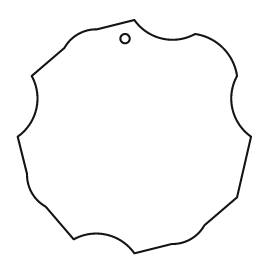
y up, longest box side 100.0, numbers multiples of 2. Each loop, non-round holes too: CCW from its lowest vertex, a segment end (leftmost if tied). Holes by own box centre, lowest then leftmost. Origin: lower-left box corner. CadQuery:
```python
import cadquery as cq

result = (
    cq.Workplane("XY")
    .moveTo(50.0, 0.0)
    .lineTo(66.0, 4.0)
    .threePointArc((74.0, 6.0), (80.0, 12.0))
    .lineTo(94.0, 24.0)
    .lineTo(100.0, 50.0)
    .threePointArc((92.0, 62.0), (94.0, 76.0))
    .threePointArc((88.0, 88.0), (76.0, 94.0))
    .threePointArc((62.0, 92.0), (50.0, 100.0))
    .lineTo(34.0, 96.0)
    .threePointArc((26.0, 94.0), (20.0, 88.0))
    .lineTo(6.0, 76.0)
    .threePointArc((8.0, 62.0), (0.0, 50.0))
    .lineTo(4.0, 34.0)
    .threePointArc((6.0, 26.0), (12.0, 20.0))
    .lineTo(24.0, 6.0)
    .threePointArc((38.0, 8.0), (50.0, 0.0))
    .close()
    .moveTo(46.0, 92.0)
    .circle(2.0)
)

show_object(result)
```